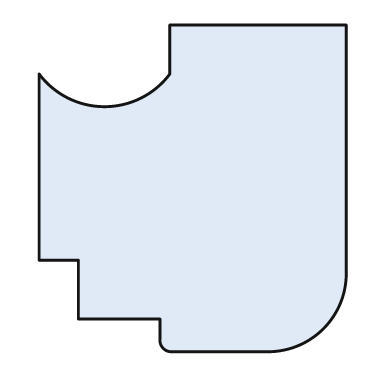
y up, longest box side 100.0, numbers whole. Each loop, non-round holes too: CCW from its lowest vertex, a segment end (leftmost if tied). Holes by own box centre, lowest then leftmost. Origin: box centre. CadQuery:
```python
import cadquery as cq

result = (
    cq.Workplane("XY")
    .moveTo(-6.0, -50.0)
    .lineTo(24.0, -50.0)
    .threePointArc((40.0, -43.0), (47.0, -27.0))
    .lineTo(47.0, 50.0)
    .lineTo(-7.0, 50.0)
    .lineTo(-7.0, 35.0)
    .threePointArc((-27.0, 25.0), (-47.0, 35.0))
    .lineTo(-47.0, -22.0)
    .lineTo(-35.0, -22.0)
    .lineTo(-35.0, -40.0)
    .lineTo(-10.0, -40.0)
    .lineTo(-10.0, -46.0)
    .threePointArc((-9.0, -49.0), (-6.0, -50.0))
    .close()
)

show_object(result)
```